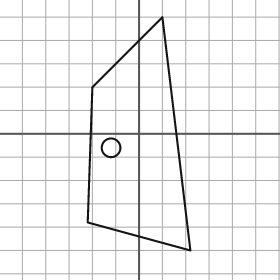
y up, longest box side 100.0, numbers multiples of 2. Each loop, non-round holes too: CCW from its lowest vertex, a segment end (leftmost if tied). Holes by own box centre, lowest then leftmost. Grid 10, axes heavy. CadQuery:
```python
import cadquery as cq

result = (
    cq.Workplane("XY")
    .moveTo(22.0, -50.0)
    .lineTo(10.0, 50.0)
    .lineTo(-20.0, 20.0)
    .lineTo(-22.0, -38.0)
    .close()
    .moveTo(-12.0, -6.0)
    .circle(4.0)
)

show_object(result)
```